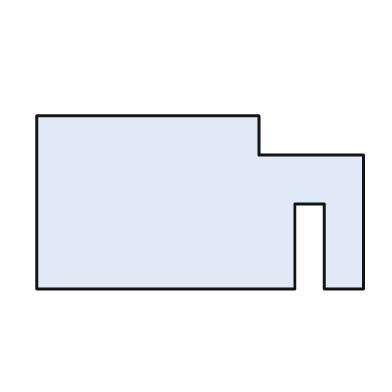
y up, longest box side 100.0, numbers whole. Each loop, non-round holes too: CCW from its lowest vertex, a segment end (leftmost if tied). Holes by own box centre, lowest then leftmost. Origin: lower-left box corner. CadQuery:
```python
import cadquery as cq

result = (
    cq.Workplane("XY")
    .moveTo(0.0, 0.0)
    .lineTo(79.0, 0.0)
    .lineTo(79.0, 26.0)
    .lineTo(88.0, 26.0)
    .lineTo(88.0, 0.0)
    .lineTo(100.0, 0.0)
    .lineTo(100.0, 41.0)
    .lineTo(68.0, 41.0)
    .lineTo(68.0, 53.0)
    .lineTo(0.0, 53.0)
    .close()
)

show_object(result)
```